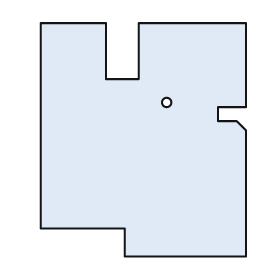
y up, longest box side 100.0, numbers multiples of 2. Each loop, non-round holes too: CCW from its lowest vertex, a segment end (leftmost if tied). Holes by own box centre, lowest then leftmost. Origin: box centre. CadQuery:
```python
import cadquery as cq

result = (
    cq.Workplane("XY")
    .moveTo(-8.0, -50.0)
    .lineTo(44.0, -50.0)
    .lineTo(44.0, 4.0)
    .lineTo(40.0, 8.0)
    .lineTo(32.0, 8.0)
    .lineTo(32.0, 14.0)
    .lineTo(44.0, 14.0)
    .lineTo(44.0, 50.0)
    .lineTo(-2.0, 50.0)
    .lineTo(-2.0, 26.0)
    .lineTo(-16.0, 26.0)
    .lineTo(-16.0, 50.0)
    .lineTo(-44.0, 50.0)
    .lineTo(-44.0, -38.0)
    .lineTo(-8.0, -38.0)
    .close()
    .moveTo(10.0, 16.0)
    .circle(2.0)
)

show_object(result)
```